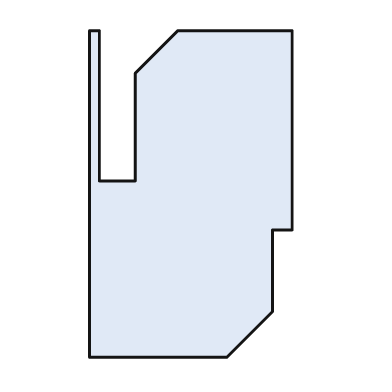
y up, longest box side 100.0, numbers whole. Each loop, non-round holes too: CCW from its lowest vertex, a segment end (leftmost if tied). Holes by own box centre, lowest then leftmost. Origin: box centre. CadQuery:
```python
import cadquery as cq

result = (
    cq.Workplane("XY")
    .moveTo(-31.0, -50.0)
    .lineTo(11.0, -50.0)
    .lineTo(25.0, -36.0)
    .lineTo(25.0, -11.0)
    .lineTo(31.0, -11.0)
    .lineTo(31.0, 50.0)
    .lineTo(-4.0, 50.0)
    .lineTo(-17.0, 37.0)
    .lineTo(-17.0, 4.0)
    .lineTo(-28.0, 4.0)
    .lineTo(-28.0, 50.0)
    .lineTo(-31.0, 50.0)
    .close()
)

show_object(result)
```